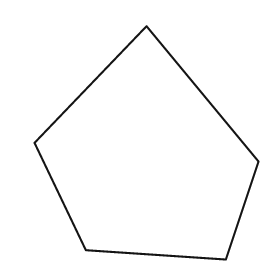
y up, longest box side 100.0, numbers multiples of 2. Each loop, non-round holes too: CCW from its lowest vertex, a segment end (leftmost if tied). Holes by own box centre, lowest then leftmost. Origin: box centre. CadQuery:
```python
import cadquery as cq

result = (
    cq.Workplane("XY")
    .moveTo(34.0, -50.0)
    .lineTo(48.0, -8.0)
    .lineTo(0.0, 50.0)
    .lineTo(-48.0, 0.0)
    .lineTo(-26.0, -46.0)
    .close()
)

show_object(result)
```